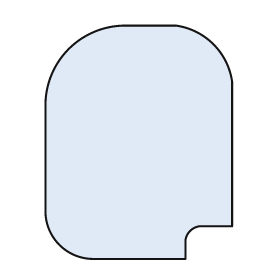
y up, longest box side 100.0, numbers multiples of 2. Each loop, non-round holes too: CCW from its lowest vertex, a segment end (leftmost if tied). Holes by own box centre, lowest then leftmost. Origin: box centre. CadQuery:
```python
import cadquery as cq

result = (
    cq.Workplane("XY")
    .moveTo(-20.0, -50.0)
    .lineTo(20.0, -50.0)
    .lineTo(20.0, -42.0)
    .threePointArc((22.0, -38.0), (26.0, -36.0))
    .lineTo(40.0, -36.0)
    .lineTo(40.0, 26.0)
    .threePointArc((32.0, 42.0), (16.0, 50.0))
    .lineTo(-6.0, 50.0)
    .threePointArc((-30.0, 40.0), (-40.0, 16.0))
    .lineTo(-40.0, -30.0)
    .threePointArc((-34.0, -44.0), (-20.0, -50.0))
    .close()
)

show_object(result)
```